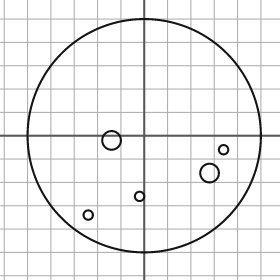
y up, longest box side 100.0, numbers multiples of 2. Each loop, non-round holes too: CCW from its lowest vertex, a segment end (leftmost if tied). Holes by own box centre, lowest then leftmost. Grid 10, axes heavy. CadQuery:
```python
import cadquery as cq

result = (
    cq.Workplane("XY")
    .moveTo(0.0, 0.0)
    .circle(50.0)
    .moveTo(-24.0, -34.0)
    .circle(2.0)
    .moveTo(-2.0, -26.0)
    .circle(2.0)
    .moveTo(28.0, -16.0)
    .circle(4.0)
    .moveTo(34.0, -6.0)
    .circle(2.0)
    .moveTo(-14.0, -2.0)
    .circle(4.0)
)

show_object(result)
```